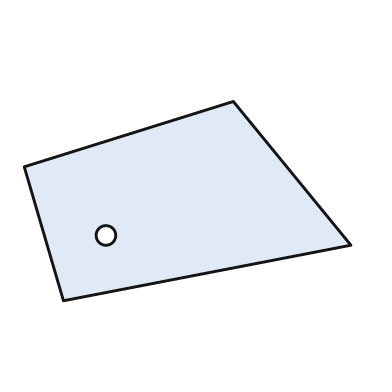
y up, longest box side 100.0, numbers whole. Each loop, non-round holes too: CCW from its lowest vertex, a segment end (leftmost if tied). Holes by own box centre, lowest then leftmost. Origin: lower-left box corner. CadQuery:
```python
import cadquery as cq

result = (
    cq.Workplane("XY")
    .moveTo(12.0, 0.0)
    .lineTo(100.0, 17.0)
    .lineTo(64.0, 61.0)
    .lineTo(0.0, 41.0)
    .close()
    .moveTo(25.0, 20.0)
    .circle(3.0)
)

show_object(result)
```